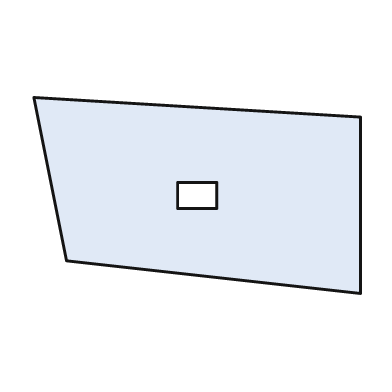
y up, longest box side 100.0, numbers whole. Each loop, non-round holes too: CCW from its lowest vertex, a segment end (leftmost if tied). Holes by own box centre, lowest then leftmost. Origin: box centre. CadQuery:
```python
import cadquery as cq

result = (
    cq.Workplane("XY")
    .moveTo(50.0, -30.0)
    .lineTo(50.0, 24.0)
    .lineTo(-50.0, 30.0)
    .lineTo(-40.0, -20.0)
    .close()
    .moveTo(-6.0, -4.0)
    .lineTo(6.0, -4.0)
    .lineTo(6.0, 4.0)
    .lineTo(-6.0, 4.0)
    .close()
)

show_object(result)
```